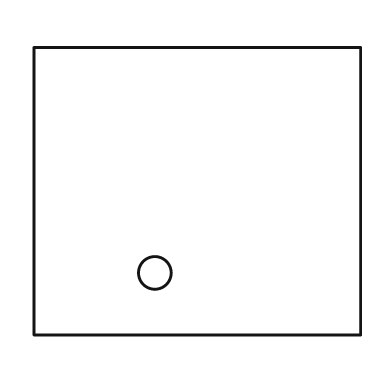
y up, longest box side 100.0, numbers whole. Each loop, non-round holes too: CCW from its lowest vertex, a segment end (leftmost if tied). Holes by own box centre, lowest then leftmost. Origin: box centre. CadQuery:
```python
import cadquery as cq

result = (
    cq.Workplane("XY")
    .moveTo(-50.0, -44.0)
    .lineTo(50.0, -44.0)
    .lineTo(50.0, 44.0)
    .lineTo(-50.0, 44.0)
    .close()
    .moveTo(-13.0, -25.0)
    .circle(5.0)
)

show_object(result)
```